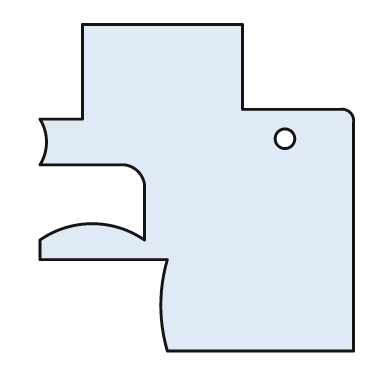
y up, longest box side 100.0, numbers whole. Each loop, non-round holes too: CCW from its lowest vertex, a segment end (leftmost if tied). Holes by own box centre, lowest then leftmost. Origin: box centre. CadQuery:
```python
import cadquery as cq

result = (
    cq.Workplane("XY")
    .moveTo(-9.0, -50.0)
    .lineTo(48.0, -50.0)
    .lineTo(48.0, 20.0)
    .threePointArc((47.0, 23.0), (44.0, 24.0))
    .lineTo(14.0, 24.0)
    .lineTo(14.0, 50.0)
    .lineTo(-35.0, 50.0)
    .lineTo(-35.0, 21.0)
    .lineTo(-48.0, 21.0)
    .threePointArc((-46.0, 14.0), (-48.0, 7.0))
    .lineTo(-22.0, 7.0)
    .threePointArc((-18.0, 5.0), (-16.0, 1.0))
    .lineTo(-16.0, -16.0)
    .threePointArc((-32.0, -11.0), (-48.0, -16.0))
    .lineTo(-48.0, -22.0)
    .lineTo(-9.0, -22.0)
    .threePointArc((-11.0, -36.0), (-9.0, -50.0))
    .close()
    .moveTo(27.0, 15.0)
    .circle(3.0)
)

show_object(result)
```